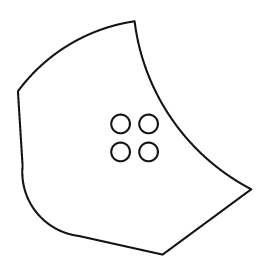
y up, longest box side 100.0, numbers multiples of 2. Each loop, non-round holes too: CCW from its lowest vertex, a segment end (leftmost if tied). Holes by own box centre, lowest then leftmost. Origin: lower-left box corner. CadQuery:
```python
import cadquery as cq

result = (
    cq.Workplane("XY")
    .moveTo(62.0, 0.0)
    .lineTo(100.0, 28.0)
    .threePointArc((66.0, 58.0), (50.0, 100.0))
    .threePointArc((22.0, 90.0), (0.0, 70.0))
    .lineTo(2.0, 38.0)
    .threePointArc((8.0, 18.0), (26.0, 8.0))
    .close()
    .moveTo(44.0, 44.0)
    .circle(4.0)
    .moveTo(56.0, 44.0)
    .circle(4.0)
    .moveTo(44.0, 56.0)
    .circle(4.0)
    .moveTo(56.0, 56.0)
    .circle(4.0)
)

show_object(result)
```